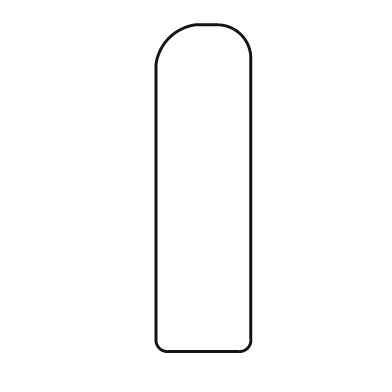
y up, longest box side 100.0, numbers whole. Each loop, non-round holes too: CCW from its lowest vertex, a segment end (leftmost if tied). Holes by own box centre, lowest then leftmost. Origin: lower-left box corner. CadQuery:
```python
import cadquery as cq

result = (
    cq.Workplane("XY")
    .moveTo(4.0, 0.0)
    .lineTo(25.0, 0.0)
    .threePointArc((28.0, 1.0), (29.0, 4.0))
    .lineTo(29.0, 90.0)
    .threePointArc((26.0, 97.0), (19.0, 100.0))
    .lineTo(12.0, 100.0)
    .threePointArc((4.0, 96.0), (0.0, 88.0))
    .lineTo(0.0, 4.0)
    .threePointArc((1.0, 1.0), (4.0, 0.0))
    .close()
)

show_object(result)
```